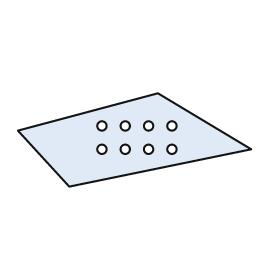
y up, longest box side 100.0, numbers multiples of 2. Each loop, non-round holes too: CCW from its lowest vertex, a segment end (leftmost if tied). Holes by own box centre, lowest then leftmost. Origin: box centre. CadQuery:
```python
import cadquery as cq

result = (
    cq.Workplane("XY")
    .moveTo(-28.0, -20.0)
    .lineTo(50.0, -4.0)
    .lineTo(10.0, 20.0)
    .lineTo(-50.0, 4.0)
    .close()
    .moveTo(-14.0, -4.0)
    .circle(2.0)
    .moveTo(-4.0, -4.0)
    .circle(2.0)
    .moveTo(6.0, -4.0)
    .circle(2.0)
    .moveTo(16.0, -4.0)
    .circle(2.0)
    .moveTo(-14.0, 6.0)
    .circle(2.0)
    .moveTo(-4.0, 6.0)
    .circle(2.0)
    .moveTo(6.0, 6.0)
    .circle(2.0)
    .moveTo(16.0, 6.0)
    .circle(2.0)
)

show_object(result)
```